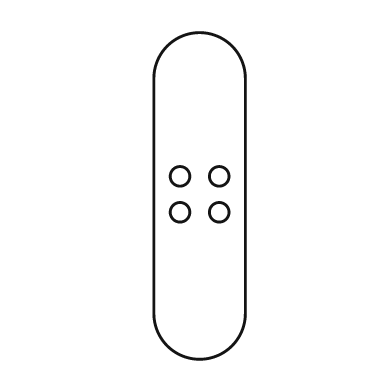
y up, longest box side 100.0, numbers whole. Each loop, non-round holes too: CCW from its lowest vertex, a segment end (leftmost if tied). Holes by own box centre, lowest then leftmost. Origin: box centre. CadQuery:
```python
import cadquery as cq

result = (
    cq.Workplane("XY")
    .moveTo(-14.0, -36.0)
    .threePointArc((0.0, -50.0), (14.0, -36.0))
    .lineTo(14.0, 36.0)
    .threePointArc((0.0, 50.0), (-14.0, 36.0))
    .close()
    .moveTo(-6.0, -5.0)
    .circle(3.0)
    .moveTo(6.0, -5.0)
    .circle(3.0)
    .moveTo(-6.0, 6.0)
    .circle(3.0)
    .moveTo(6.0, 6.0)
    .circle(3.0)
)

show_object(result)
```